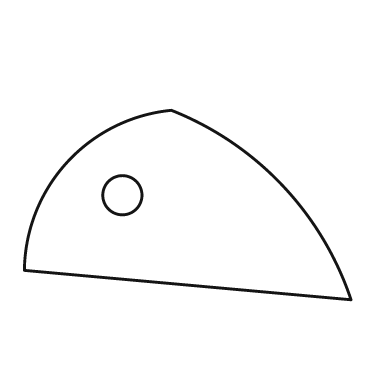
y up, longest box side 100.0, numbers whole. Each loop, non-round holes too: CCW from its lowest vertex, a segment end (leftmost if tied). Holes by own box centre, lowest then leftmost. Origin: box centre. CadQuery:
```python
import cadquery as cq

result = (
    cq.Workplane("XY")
    .moveTo(50.0, -29.0)
    .threePointArc((29.0, 6.0), (-5.0, 29.0))
    .threePointArc((-37.0, 13.0), (-50.0, -20.0))
    .close()
    .moveTo(-20.0, 3.0)
    .circle(6.0)
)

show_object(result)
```